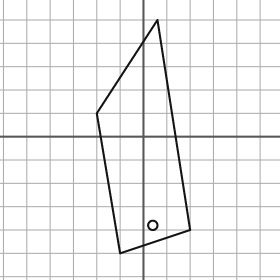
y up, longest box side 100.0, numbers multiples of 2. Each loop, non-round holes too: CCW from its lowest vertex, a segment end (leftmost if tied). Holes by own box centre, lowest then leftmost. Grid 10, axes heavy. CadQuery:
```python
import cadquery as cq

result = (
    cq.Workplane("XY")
    .moveTo(-10.0, -50.0)
    .lineTo(20.0, -40.0)
    .lineTo(6.0, 50.0)
    .lineTo(-20.0, 10.0)
    .close()
    .moveTo(4.0, -38.0)
    .circle(2.0)
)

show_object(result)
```